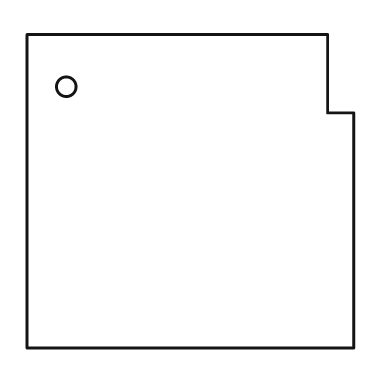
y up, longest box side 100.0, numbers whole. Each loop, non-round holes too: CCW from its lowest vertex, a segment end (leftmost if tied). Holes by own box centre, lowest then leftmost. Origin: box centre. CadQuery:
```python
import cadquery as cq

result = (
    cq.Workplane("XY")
    .moveTo(-50.0, -48.0)
    .lineTo(50.0, -48.0)
    .lineTo(50.0, 24.0)
    .lineTo(42.0, 24.0)
    .lineTo(42.0, 48.0)
    .lineTo(-50.0, 48.0)
    .close()
    .moveTo(-38.0, 32.0)
    .circle(3.0)
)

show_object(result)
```